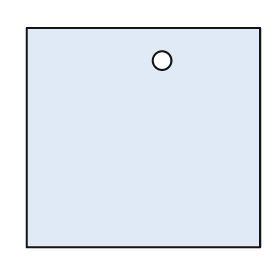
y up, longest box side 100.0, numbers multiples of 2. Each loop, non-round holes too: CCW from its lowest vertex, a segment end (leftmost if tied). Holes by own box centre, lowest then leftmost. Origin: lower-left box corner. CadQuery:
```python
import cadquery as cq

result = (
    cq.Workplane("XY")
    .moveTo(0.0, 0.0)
    .lineTo(100.0, 0.0)
    .lineTo(100.0, 94.0)
    .lineTo(0.0, 94.0)
    .close()
    .moveTo(58.0, 80.0)
    .circle(4.0)
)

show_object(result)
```